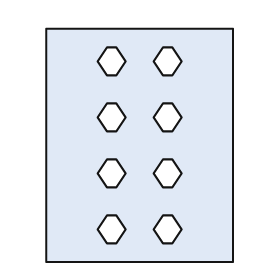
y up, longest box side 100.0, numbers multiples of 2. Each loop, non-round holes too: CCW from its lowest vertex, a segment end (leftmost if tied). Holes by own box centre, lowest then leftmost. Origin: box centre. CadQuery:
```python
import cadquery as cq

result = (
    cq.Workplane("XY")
    .moveTo(-40.0, -50.0)
    .lineTo(40.0, -50.0)
    .lineTo(40.0, 50.0)
    .lineTo(-40.0, 50.0)
    .close()
    .moveTo(-14.0, -42.0)
    .lineTo(-10.0, -42.0)
    .lineTo(-6.0, -36.0)
    .lineTo(-10.0, -30.0)
    .lineTo(-14.0, -30.0)
    .lineTo(-18.0, -36.0)
    .close()
    .moveTo(10.0, -42.0)
    .lineTo(14.0, -42.0)
    .lineTo(18.0, -36.0)
    .lineTo(14.0, -30.0)
    .lineTo(10.0, -30.0)
    .lineTo(6.0, -36.0)
    .close()
    .moveTo(-14.0, -18.0)
    .lineTo(-10.0, -18.0)
    .lineTo(-6.0, -12.0)
    .lineTo(-10.0, -6.0)
    .lineTo(-14.0, -6.0)
    .lineTo(-18.0, -12.0)
    .close()
    .moveTo(10.0, -18.0)
    .lineTo(14.0, -18.0)
    .lineTo(18.0, -12.0)
    .lineTo(14.0, -6.0)
    .lineTo(10.0, -6.0)
    .lineTo(6.0, -12.0)
    .close()
    .moveTo(-14.0, 6.0)
    .lineTo(-10.0, 6.0)
    .lineTo(-6.0, 12.0)
    .lineTo(-10.0, 18.0)
    .lineTo(-14.0, 18.0)
    .lineTo(-18.0, 12.0)
    .close()
    .moveTo(10.0, 6.0)
    .lineTo(14.0, 6.0)
    .lineTo(18.0, 12.0)
    .lineTo(14.0, 18.0)
    .lineTo(10.0, 18.0)
    .lineTo(6.0, 12.0)
    .close()
    .moveTo(-14.0, 30.0)
    .lineTo(-10.0, 30.0)
    .lineTo(-6.0, 36.0)
    .lineTo(-10.0, 42.0)
    .lineTo(-14.0, 42.0)
    .lineTo(-18.0, 36.0)
    .close()
    .moveTo(10.0, 30.0)
    .lineTo(14.0, 30.0)
    .lineTo(18.0, 36.0)
    .lineTo(14.0, 42.0)
    .lineTo(10.0, 42.0)
    .lineTo(6.0, 36.0)
    .close()
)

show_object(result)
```